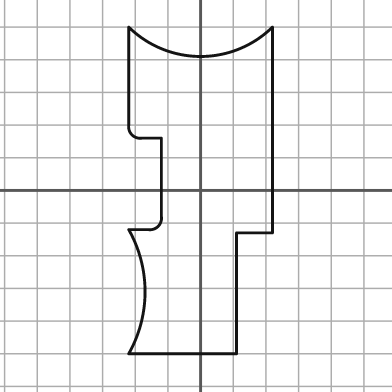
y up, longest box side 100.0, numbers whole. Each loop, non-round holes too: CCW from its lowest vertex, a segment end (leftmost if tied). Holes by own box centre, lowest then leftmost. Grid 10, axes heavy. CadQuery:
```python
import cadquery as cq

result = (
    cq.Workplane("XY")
    .moveTo(-22.0, -50.0)
    .lineTo(11.0, -50.0)
    .lineTo(11.0, -13.0)
    .lineTo(22.0, -13.0)
    .lineTo(22.0, 50.0)
    .threePointArc((0.0, 41.0), (-22.0, 50.0))
    .lineTo(-22.0, 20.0)
    .threePointArc((-21.0, 17.0), (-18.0, 16.0))
    .lineTo(-12.0, 16.0)
    .lineTo(-12.0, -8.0)
    .threePointArc((-13.0, -11.0), (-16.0, -12.0))
    .lineTo(-22.0, -12.0)
    .threePointArc((-17.0, -31.0), (-22.0, -50.0))
    .close()
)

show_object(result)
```